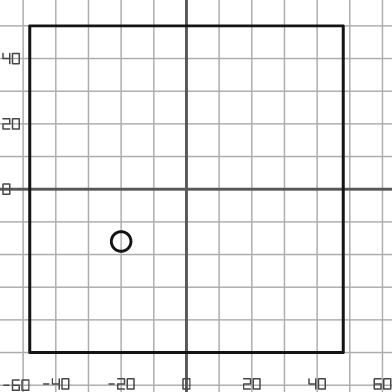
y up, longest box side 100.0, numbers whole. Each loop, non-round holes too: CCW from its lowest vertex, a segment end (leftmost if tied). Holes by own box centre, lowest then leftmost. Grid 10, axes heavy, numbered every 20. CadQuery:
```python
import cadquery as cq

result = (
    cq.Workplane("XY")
    .moveTo(-48.0, -50.0)
    .lineTo(48.0, -50.0)
    .lineTo(48.0, 50.0)
    .lineTo(-48.0, 50.0)
    .close()
    .moveTo(-20.0, -16.0)
    .circle(3.0)
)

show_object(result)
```